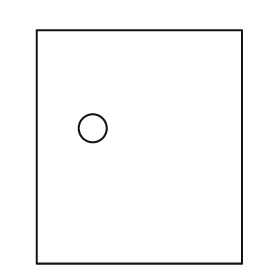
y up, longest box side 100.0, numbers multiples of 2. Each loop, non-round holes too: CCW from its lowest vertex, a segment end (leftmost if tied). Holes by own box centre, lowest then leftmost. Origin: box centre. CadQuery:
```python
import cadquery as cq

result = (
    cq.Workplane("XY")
    .moveTo(-44.0, -50.0)
    .lineTo(44.0, -50.0)
    .lineTo(44.0, 50.0)
    .lineTo(-44.0, 50.0)
    .close()
    .moveTo(-20.0, 8.0)
    .circle(6.0)
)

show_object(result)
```